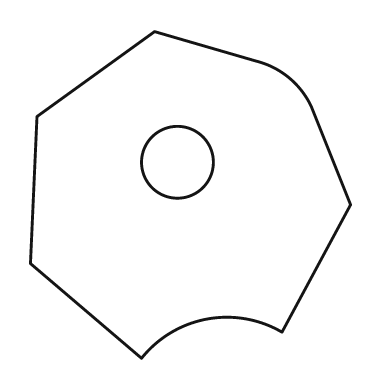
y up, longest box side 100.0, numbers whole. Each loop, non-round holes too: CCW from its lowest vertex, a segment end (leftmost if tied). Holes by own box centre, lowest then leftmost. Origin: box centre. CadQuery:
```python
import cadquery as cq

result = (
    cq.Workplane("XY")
    .moveTo(-15.0, -50.0)
    .threePointArc((5.0, -38.0), (28.0, -42.0))
    .lineTo(49.0, -3.0)
    .lineTo(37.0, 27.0)
    .threePointArc((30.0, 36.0), (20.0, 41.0))
    .lineTo(-11.0, 50.0)
    .lineTo(-47.0, 24.0)
    .lineTo(-49.0, -21.0)
    .close()
    .moveTo(-4.0, 10.0)
    .circle(11.0)
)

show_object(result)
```